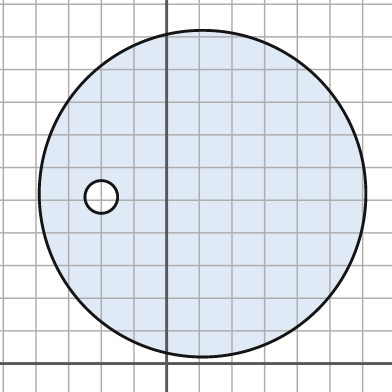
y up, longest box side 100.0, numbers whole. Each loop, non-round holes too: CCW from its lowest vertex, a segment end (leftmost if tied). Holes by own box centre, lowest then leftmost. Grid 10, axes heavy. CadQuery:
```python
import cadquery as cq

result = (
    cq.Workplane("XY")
    .moveTo(11.0, 52.0)
    .circle(50.0)
    .moveTo(-20.0, 51.0)
    .circle(5.0)
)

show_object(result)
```